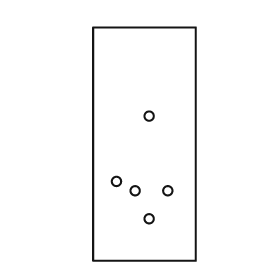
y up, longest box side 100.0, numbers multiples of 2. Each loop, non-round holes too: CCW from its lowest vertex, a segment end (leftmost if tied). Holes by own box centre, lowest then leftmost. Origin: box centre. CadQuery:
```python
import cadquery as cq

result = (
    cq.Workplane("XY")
    .moveTo(-22.0, -50.0)
    .lineTo(22.0, -50.0)
    .lineTo(22.0, 50.0)
    .lineTo(-22.0, 50.0)
    .close()
    .moveTo(2.0, -32.0)
    .circle(2.0)
    .moveTo(-4.0, -20.0)
    .circle(2.0)
    .moveTo(10.0, -20.0)
    .circle(2.0)
    .moveTo(-12.0, -16.0)
    .circle(2.0)
    .moveTo(2.0, 12.0)
    .circle(2.0)
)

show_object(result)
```